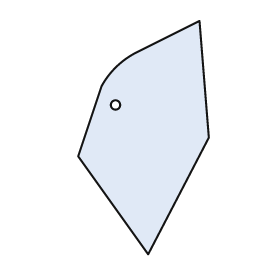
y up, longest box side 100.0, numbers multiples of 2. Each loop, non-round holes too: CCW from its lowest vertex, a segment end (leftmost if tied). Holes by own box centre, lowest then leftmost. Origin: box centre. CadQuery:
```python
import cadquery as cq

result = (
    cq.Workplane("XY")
    .moveTo(2.0, -50.0)
    .lineTo(28.0, 0.0)
    .lineTo(24.0, 50.0)
    .lineTo(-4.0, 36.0)
    .threePointArc((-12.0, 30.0), (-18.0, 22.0))
    .lineTo(-28.0, -8.0)
    .close()
    .moveTo(-12.0, 14.0)
    .circle(2.0)
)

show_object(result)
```